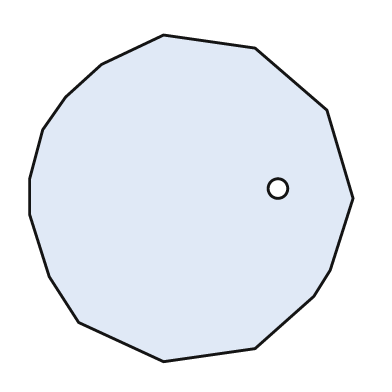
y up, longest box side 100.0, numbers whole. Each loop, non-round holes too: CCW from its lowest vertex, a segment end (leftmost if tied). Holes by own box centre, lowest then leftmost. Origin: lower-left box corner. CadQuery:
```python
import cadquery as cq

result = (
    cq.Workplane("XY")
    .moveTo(41.0, 0.0)
    .lineTo(69.0, 4.0)
    .lineTo(87.0, 20.0)
    .lineTo(92.0, 28.0)
    .lineTo(99.0, 50.0)
    .lineTo(91.0, 77.0)
    .lineTo(69.0, 96.0)
    .lineTo(41.0, 100.0)
    .lineTo(22.0, 91.0)
    .lineTo(11.0, 81.0)
    .lineTo(4.0, 71.0)
    .lineTo(0.0, 56.0)
    .lineTo(0.0, 45.0)
    .lineTo(6.0, 26.0)
    .lineTo(15.0, 12.0)
    .close()
    .moveTo(76.0, 53.0)
    .circle(3.0)
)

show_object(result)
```